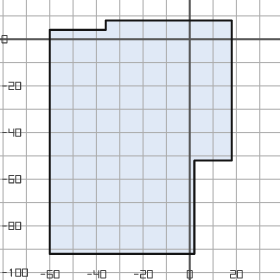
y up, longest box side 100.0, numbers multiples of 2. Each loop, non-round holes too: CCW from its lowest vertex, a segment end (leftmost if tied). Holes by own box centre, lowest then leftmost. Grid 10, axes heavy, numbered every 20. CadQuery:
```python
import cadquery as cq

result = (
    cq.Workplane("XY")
    .moveTo(-60.0, -92.0)
    .lineTo(2.0, -92.0)
    .lineTo(2.0, -52.0)
    .lineTo(18.0, -52.0)
    .lineTo(18.0, 8.0)
    .lineTo(-36.0, 8.0)
    .lineTo(-36.0, 4.0)
    .lineTo(-60.0, 4.0)
    .close()
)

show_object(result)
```